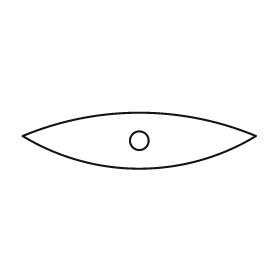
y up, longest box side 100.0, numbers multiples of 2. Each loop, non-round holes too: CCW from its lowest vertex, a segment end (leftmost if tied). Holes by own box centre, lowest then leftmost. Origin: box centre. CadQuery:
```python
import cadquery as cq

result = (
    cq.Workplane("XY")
    .moveTo(-50.0, 2.0)
    .threePointArc((0.0, -12.0), (50.0, 2.0))
    .threePointArc((0.0, 12.0), (-50.0, 2.0))
    .close()
    .moveTo(0.0, 0.0)
    .circle(4.0)
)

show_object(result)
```